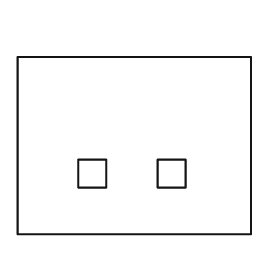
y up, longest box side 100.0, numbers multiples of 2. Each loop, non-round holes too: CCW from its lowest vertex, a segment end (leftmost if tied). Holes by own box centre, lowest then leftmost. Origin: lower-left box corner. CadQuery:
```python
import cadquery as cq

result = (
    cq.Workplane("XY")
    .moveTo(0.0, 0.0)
    .lineTo(100.0, 0.0)
    .lineTo(100.0, 76.0)
    .lineTo(0.0, 76.0)
    .close()
    .moveTo(26.0, 20.0)
    .lineTo(38.0, 20.0)
    .lineTo(38.0, 32.0)
    .lineTo(26.0, 32.0)
    .close()
    .moveTo(60.0, 20.0)
    .lineTo(72.0, 20.0)
    .lineTo(72.0, 32.0)
    .lineTo(60.0, 32.0)
    .close()
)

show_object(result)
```